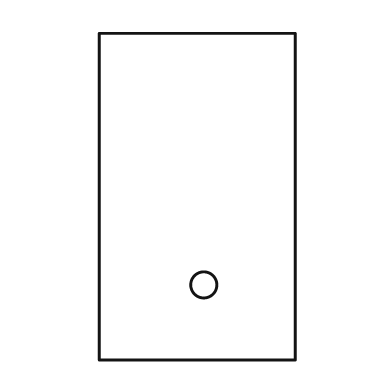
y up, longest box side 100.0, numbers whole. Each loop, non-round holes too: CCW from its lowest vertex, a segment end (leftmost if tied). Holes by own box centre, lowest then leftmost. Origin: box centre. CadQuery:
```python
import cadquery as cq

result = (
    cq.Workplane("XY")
    .moveTo(-30.0, -50.0)
    .lineTo(30.0, -50.0)
    .lineTo(30.0, 50.0)
    .lineTo(-30.0, 50.0)
    .close()
    .moveTo(2.0, -27.0)
    .circle(4.0)
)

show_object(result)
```